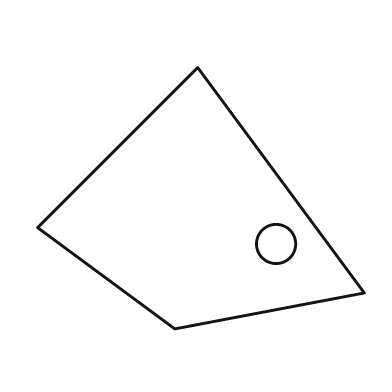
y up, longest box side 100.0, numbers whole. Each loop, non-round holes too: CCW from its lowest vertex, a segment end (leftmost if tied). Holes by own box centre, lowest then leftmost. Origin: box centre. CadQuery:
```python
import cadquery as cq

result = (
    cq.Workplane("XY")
    .moveTo(-8.0, -40.0)
    .lineTo(50.0, -29.0)
    .lineTo(-1.0, 40.0)
    .lineTo(-50.0, -9.0)
    .close()
    .moveTo(23.0, -14.0)
    .circle(6.0)
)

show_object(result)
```